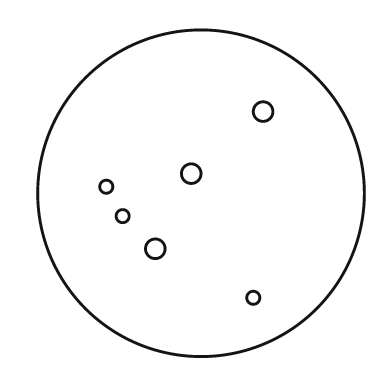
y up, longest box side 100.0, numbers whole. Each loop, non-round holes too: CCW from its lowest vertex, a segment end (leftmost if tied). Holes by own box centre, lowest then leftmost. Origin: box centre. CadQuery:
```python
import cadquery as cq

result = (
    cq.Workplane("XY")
    .moveTo(0.0, 0.0)
    .circle(50.0)
    .moveTo(16.0, -32.0)
    .circle(2.0)
    .moveTo(-14.0, -17.0)
    .circle(3.0)
    .moveTo(-24.0, -7.0)
    .circle(2.0)
    .moveTo(-29.0, 2.0)
    .circle(2.0)
    .moveTo(-3.0, 6.0)
    .circle(3.0)
    .moveTo(19.0, 25.0)
    .circle(3.0)
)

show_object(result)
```